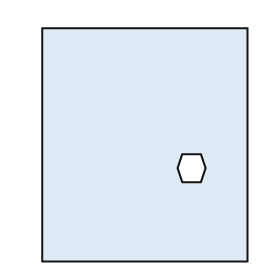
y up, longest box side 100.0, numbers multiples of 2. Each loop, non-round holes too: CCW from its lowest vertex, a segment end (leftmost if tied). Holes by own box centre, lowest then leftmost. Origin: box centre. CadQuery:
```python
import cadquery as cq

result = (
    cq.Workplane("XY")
    .moveTo(-44.0, -50.0)
    .lineTo(44.0, -50.0)
    .lineTo(44.0, 50.0)
    .lineTo(-44.0, 50.0)
    .close()
    .moveTo(16.0, -16.0)
    .lineTo(24.0, -16.0)
    .lineTo(26.0, -10.0)
    .lineTo(24.0, -4.0)
    .lineTo(16.0, -4.0)
    .lineTo(14.0, -10.0)
    .close()
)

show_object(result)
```